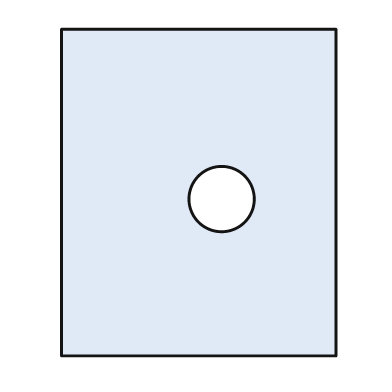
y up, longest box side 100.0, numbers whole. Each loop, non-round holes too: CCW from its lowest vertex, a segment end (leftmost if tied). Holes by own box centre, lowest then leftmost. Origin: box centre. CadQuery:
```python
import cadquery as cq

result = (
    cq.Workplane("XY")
    .moveTo(-42.0, -50.0)
    .lineTo(42.0, -50.0)
    .lineTo(42.0, 50.0)
    .lineTo(-42.0, 50.0)
    .close()
    .moveTo(7.0, -2.0)
    .circle(10.0)
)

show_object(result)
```